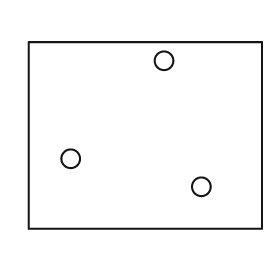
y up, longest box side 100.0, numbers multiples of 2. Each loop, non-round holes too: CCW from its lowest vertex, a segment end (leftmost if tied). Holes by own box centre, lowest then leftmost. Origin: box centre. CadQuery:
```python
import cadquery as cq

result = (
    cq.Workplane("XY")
    .moveTo(-50.0, -40.0)
    .lineTo(50.0, -40.0)
    .lineTo(50.0, 40.0)
    .lineTo(-50.0, 40.0)
    .close()
    .moveTo(24.0, -22.0)
    .circle(4.0)
    .moveTo(-32.0, -10.0)
    .circle(4.0)
    .moveTo(8.0, 32.0)
    .circle(4.0)
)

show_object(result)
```